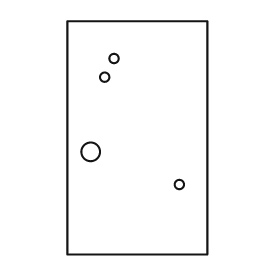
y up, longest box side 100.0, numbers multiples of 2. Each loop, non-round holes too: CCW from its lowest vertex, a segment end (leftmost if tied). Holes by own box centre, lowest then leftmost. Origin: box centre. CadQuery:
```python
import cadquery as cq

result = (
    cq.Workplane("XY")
    .moveTo(-30.0, -50.0)
    .lineTo(30.0, -50.0)
    .lineTo(30.0, 50.0)
    .lineTo(-30.0, 50.0)
    .close()
    .moveTo(18.0, -20.0)
    .circle(2.0)
    .moveTo(-20.0, -6.0)
    .circle(4.0)
    .moveTo(-14.0, 26.0)
    .circle(2.0)
    .moveTo(-10.0, 34.0)
    .circle(2.0)
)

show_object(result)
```